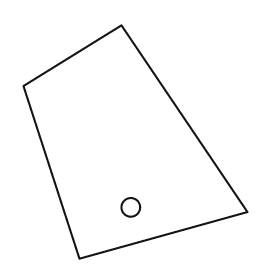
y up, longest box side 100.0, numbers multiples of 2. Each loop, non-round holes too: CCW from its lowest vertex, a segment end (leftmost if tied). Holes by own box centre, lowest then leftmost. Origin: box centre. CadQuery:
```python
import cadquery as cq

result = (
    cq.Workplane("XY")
    .moveTo(-24.0, -50.0)
    .lineTo(48.0, -30.0)
    .lineTo(-6.0, 50.0)
    .lineTo(-48.0, 24.0)
    .close()
    .moveTo(-2.0, -28.0)
    .circle(4.0)
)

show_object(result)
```